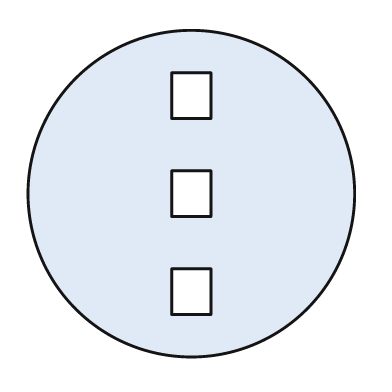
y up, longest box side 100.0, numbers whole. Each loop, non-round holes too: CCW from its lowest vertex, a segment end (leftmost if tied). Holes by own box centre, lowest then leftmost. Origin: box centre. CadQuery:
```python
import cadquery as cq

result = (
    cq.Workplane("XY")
    .moveTo(0.0, 0.0)
    .circle(50.0)
    .moveTo(-6.0, -37.0)
    .lineTo(6.0, -37.0)
    .lineTo(6.0, -23.0)
    .lineTo(-6.0, -23.0)
    .close()
    .moveTo(-6.0, -7.0)
    .lineTo(6.0, -7.0)
    .lineTo(6.0, 7.0)
    .lineTo(-6.0, 7.0)
    .close()
    .moveTo(-6.0, 23.0)
    .lineTo(6.0, 23.0)
    .lineTo(6.0, 37.0)
    .lineTo(-6.0, 37.0)
    .close()
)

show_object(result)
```